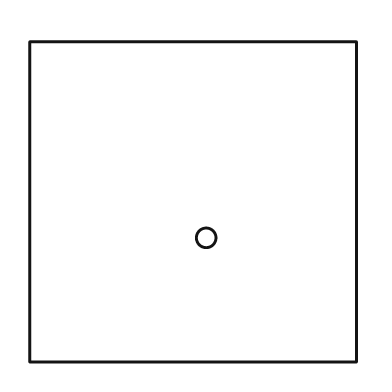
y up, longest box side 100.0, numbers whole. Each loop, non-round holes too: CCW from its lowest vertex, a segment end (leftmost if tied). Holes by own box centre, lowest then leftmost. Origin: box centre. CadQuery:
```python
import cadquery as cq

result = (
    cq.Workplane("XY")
    .moveTo(-50.0, -49.0)
    .lineTo(50.0, -49.0)
    .lineTo(50.0, 49.0)
    .lineTo(-50.0, 49.0)
    .close()
    .moveTo(4.0, -11.0)
    .circle(3.0)
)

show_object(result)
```